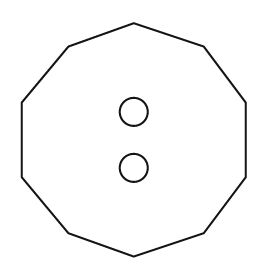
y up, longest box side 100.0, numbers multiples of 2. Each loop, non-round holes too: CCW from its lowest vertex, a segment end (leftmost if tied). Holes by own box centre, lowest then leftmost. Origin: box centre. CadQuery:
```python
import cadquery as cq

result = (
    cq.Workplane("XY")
    .moveTo(0.0, -50.0)
    .lineTo(30.0, -40.0)
    .lineTo(48.0, -16.0)
    .lineTo(48.0, 16.0)
    .lineTo(30.0, 40.0)
    .lineTo(0.0, 50.0)
    .lineTo(-28.0, 40.0)
    .lineTo(-48.0, 16.0)
    .lineTo(-48.0, -16.0)
    .lineTo(-28.0, -40.0)
    .close()
    .moveTo(0.0, -12.0)
    .circle(6.0)
    .moveTo(0.0, 12.0)
    .circle(6.0)
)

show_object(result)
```